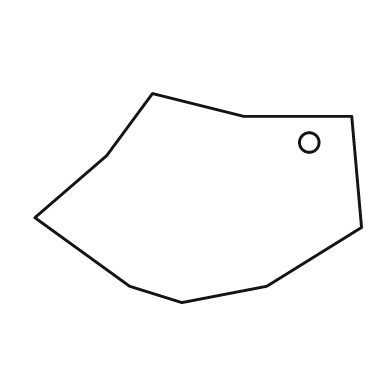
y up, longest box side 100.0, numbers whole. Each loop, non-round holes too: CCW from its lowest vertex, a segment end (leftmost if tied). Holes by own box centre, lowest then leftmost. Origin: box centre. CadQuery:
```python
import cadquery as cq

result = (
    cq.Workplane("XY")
    .moveTo(-5.0, -32.0)
    .lineTo(21.0, -27.0)
    .lineTo(50.0, -9.0)
    .lineTo(47.0, 25.0)
    .lineTo(14.0, 25.0)
    .lineTo(-14.0, 32.0)
    .lineTo(-28.0, 13.0)
    .lineTo(-50.0, -6.0)
    .lineTo(-21.0, -27.0)
    .close()
    .moveTo(34.0, 17.0)
    .circle(3.0)
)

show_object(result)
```